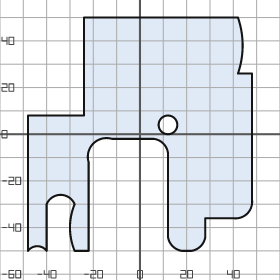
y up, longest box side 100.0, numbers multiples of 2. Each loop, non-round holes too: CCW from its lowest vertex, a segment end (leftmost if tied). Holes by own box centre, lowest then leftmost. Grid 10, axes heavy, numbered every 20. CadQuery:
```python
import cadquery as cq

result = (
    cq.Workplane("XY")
    .moveTo(-48.0, -50.0)
    .threePointArc((-44.0, -48.0), (-40.0, -50.0))
    .lineTo(-40.0, -30.0)
    .threePointArc((-34.0, -26.0), (-28.0, -30.0))
    .threePointArc((-30.0, -40.0), (-28.0, -50.0))
    .lineTo(-22.0, -50.0)
    .lineTo(-22.0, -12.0)
    .threePointArc((-20.0, -4.0), (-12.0, -2.0))
    .lineTo(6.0, -2.0)
    .threePointArc((10.0, -4.0), (12.0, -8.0))
    .lineTo(12.0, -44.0)
    .threePointArc((14.0, -48.0), (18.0, -50.0))
    .lineTo(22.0, -50.0)
    .threePointArc((26.0, -48.0), (28.0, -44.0))
    .lineTo(28.0, -36.0)
    .lineTo(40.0, -36.0)
    .threePointArc((46.0, -34.0), (48.0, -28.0))
    .lineTo(48.0, 26.0)
    .lineTo(42.0, 26.0)
    .threePointArc((44.0, 38.0), (42.0, 50.0))
    .lineTo(-24.0, 50.0)
    .lineTo(-24.0, 8.0)
    .lineTo(-48.0, 8.0)
    .close()
    .moveTo(12.0, 4.0)
    .circle(4.0)
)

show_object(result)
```